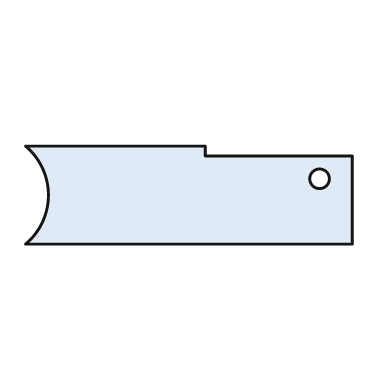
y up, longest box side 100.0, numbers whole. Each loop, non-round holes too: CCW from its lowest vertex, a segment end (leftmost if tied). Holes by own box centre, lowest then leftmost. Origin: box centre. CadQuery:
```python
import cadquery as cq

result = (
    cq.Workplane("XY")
    .moveTo(-50.0, -15.0)
    .lineTo(50.0, -15.0)
    .lineTo(50.0, 12.0)
    .lineTo(5.0, 12.0)
    .lineTo(5.0, 15.0)
    .lineTo(-50.0, 15.0)
    .threePointArc((-43.0, 0.0), (-50.0, -15.0))
    .close()
    .moveTo(40.0, 5.0)
    .circle(3.0)
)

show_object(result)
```